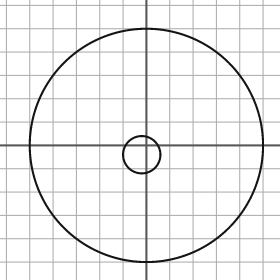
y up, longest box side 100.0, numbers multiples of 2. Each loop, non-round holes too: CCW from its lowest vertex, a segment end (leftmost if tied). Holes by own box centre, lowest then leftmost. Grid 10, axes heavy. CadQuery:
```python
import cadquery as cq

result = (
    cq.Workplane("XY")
    .moveTo(0.0, 0.0)
    .circle(50.0)
    .moveTo(-2.0, -4.0)
    .circle(8.0)
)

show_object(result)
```